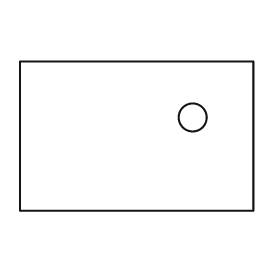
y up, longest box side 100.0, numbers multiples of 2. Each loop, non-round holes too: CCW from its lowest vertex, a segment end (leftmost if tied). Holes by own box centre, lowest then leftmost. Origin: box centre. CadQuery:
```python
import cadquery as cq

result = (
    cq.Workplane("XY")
    .moveTo(-50.0, -32.0)
    .lineTo(50.0, -32.0)
    .lineTo(50.0, 32.0)
    .lineTo(-50.0, 32.0)
    .close()
    .moveTo(24.0, 8.0)
    .circle(6.0)
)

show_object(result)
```